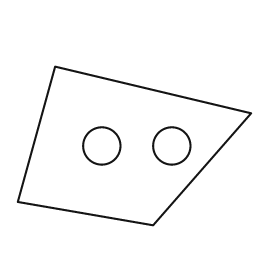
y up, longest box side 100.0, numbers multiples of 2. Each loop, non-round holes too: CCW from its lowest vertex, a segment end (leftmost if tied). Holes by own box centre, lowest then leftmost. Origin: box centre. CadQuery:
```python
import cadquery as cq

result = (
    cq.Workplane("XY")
    .moveTo(8.0, -34.0)
    .lineTo(50.0, 14.0)
    .lineTo(-34.0, 34.0)
    .lineTo(-50.0, -24.0)
    .close()
    .moveTo(-14.0, 0.0)
    .circle(8.0)
    .moveTo(16.0, 0.0)
    .circle(8.0)
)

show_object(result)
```